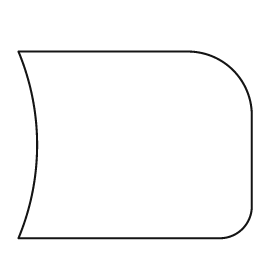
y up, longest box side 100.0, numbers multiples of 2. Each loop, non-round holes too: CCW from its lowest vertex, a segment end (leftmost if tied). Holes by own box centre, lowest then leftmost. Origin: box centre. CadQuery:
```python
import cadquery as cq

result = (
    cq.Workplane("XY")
    .moveTo(-50.0, -40.0)
    .lineTo(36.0, -40.0)
    .threePointArc((46.0, -36.0), (50.0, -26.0))
    .lineTo(50.0, 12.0)
    .threePointArc((42.0, 32.0), (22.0, 40.0))
    .lineTo(-50.0, 40.0)
    .threePointArc((-42.0, 0.0), (-50.0, -40.0))
    .close()
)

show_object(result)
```